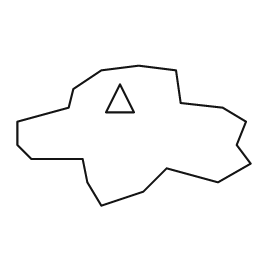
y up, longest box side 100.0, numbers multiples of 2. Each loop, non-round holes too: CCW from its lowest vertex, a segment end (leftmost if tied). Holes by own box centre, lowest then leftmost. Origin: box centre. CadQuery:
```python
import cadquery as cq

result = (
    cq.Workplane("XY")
    .moveTo(-14.0, -30.0)
    .lineTo(4.0, -24.0)
    .lineTo(14.0, -14.0)
    .lineTo(36.0, -20.0)
    .lineTo(50.0, -12.0)
    .lineTo(44.0, -4.0)
    .lineTo(48.0, 6.0)
    .lineTo(38.0, 12.0)
    .lineTo(20.0, 14.0)
    .lineTo(18.0, 28.0)
    .lineTo(2.0, 30.0)
    .lineTo(-14.0, 28.0)
    .lineTo(-26.0, 20.0)
    .lineTo(-28.0, 12.0)
    .lineTo(-50.0, 6.0)
    .lineTo(-50.0, -4.0)
    .lineTo(-44.0, -10.0)
    .lineTo(-22.0, -10.0)
    .lineTo(-20.0, -20.0)
    .close()
    .moveTo(-12.0, 10.0)
    .lineTo(0.0, 10.0)
    .lineTo(-6.0, 22.0)
    .close()
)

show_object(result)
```